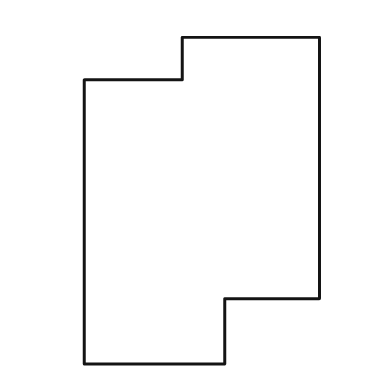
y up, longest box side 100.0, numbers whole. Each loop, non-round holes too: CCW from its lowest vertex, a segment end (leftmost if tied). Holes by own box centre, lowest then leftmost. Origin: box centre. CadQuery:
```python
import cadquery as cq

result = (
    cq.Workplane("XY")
    .moveTo(-36.0, -50.0)
    .lineTo(7.0, -50.0)
    .lineTo(7.0, -30.0)
    .lineTo(36.0, -30.0)
    .lineTo(36.0, 50.0)
    .lineTo(-6.0, 50.0)
    .lineTo(-6.0, 37.0)
    .lineTo(-36.0, 37.0)
    .close()
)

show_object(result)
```